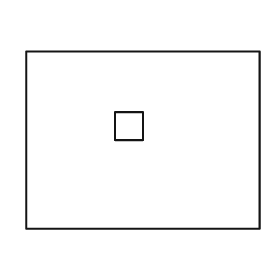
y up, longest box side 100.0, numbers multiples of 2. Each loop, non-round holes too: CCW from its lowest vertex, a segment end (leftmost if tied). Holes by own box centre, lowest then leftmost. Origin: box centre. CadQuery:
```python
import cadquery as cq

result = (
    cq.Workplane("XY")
    .moveTo(-50.0, -38.0)
    .lineTo(50.0, -38.0)
    .lineTo(50.0, 38.0)
    .lineTo(-50.0, 38.0)
    .close()
    .moveTo(-12.0, 0.0)
    .lineTo(0.0, 0.0)
    .lineTo(0.0, 12.0)
    .lineTo(-12.0, 12.0)
    .close()
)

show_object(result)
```